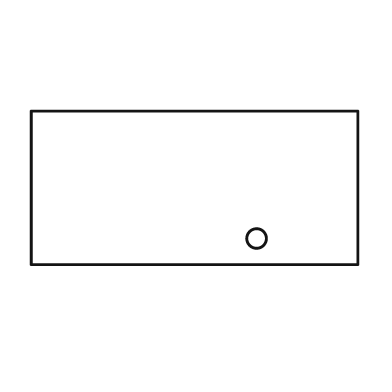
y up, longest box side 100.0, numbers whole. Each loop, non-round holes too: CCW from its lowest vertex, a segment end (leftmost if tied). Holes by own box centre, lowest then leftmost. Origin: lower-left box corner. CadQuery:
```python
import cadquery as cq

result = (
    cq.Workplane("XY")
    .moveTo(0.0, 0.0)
    .lineTo(100.0, 0.0)
    .lineTo(100.0, 47.0)
    .lineTo(0.0, 47.0)
    .close()
    .moveTo(69.0, 8.0)
    .circle(3.0)
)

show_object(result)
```